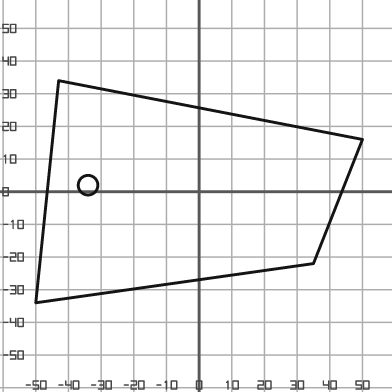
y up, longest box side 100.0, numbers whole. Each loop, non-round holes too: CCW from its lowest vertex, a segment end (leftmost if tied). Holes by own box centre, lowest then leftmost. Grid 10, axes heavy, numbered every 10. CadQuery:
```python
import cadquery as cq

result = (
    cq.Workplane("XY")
    .moveTo(-50.0, -34.0)
    .lineTo(35.0, -22.0)
    .lineTo(50.0, 16.0)
    .lineTo(-43.0, 34.0)
    .close()
    .moveTo(-34.0, 2.0)
    .circle(3.0)
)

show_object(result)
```